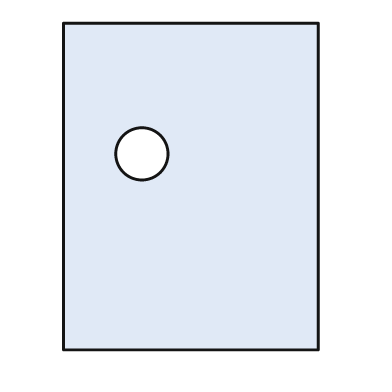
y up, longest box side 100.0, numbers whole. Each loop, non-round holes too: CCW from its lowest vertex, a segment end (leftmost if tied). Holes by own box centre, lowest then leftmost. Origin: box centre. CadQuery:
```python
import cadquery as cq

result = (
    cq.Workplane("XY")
    .moveTo(-39.0, -50.0)
    .lineTo(39.0, -50.0)
    .lineTo(39.0, 50.0)
    .lineTo(-39.0, 50.0)
    .close()
    .moveTo(-15.0, 10.0)
    .circle(8.0)
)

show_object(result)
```